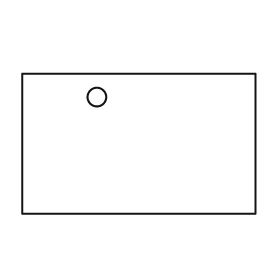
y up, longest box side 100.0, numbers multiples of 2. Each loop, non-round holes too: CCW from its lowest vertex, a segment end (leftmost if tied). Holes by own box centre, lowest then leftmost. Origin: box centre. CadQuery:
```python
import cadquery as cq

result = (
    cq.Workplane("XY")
    .moveTo(-50.0, -30.0)
    .lineTo(50.0, -30.0)
    .lineTo(50.0, 30.0)
    .lineTo(-50.0, 30.0)
    .close()
    .moveTo(-18.0, 20.0)
    .circle(4.0)
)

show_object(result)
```